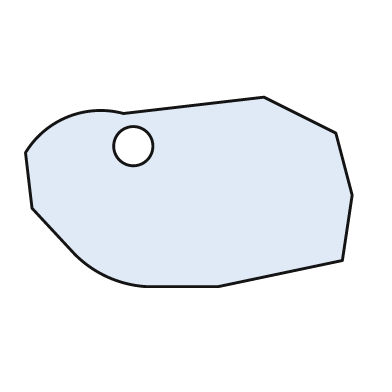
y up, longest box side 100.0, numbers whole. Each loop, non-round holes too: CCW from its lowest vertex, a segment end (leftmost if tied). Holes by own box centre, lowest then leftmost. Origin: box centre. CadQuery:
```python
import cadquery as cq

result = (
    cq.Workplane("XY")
    .moveTo(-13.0, -29.0)
    .lineTo(9.0, -29.0)
    .lineTo(47.0, -21.0)
    .lineTo(50.0, -1.0)
    .lineTo(45.0, 18.0)
    .lineTo(23.0, 29.0)
    .lineTo(-20.0, 24.0)
    .threePointArc((-37.0, 23.0), (-50.0, 12.0))
    .lineTo(-48.0, -5.0)
    .lineTo(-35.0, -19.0)
    .threePointArc((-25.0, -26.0), (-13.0, -29.0))
    .close()
    .moveTo(-17.0, 14.0)
    .circle(6.0)
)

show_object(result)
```